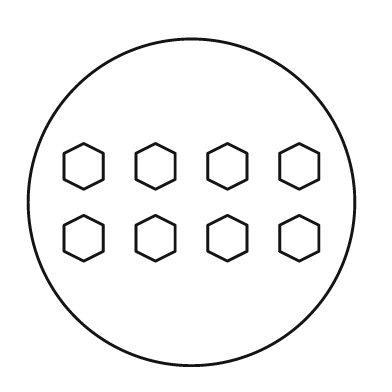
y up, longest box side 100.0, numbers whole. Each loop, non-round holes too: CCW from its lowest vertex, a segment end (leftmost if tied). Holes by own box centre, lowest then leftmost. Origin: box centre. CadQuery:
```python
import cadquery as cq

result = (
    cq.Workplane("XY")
    .moveTo(0.0, 0.0)
    .circle(50.0)
    .moveTo(-33.0, -18.0)
    .lineTo(-27.0, -15.0)
    .lineTo(-27.0, -7.0)
    .lineTo(-33.0, -4.0)
    .lineTo(-39.0, -7.0)
    .lineTo(-39.0, -15.0)
    .close()
    .moveTo(-11.0, -18.0)
    .lineTo(-5.0, -15.0)
    .lineTo(-5.0, -7.0)
    .lineTo(-11.0, -4.0)
    .lineTo(-17.0, -7.0)
    .lineTo(-17.0, -15.0)
    .close()
    .moveTo(11.0, -18.0)
    .lineTo(17.0, -15.0)
    .lineTo(17.0, -7.0)
    .lineTo(11.0, -4.0)
    .lineTo(5.0, -7.0)
    .lineTo(5.0, -15.0)
    .close()
    .moveTo(33.0, -18.0)
    .lineTo(39.0, -15.0)
    .lineTo(39.0, -7.0)
    .lineTo(33.0, -4.0)
    .lineTo(27.0, -7.0)
    .lineTo(27.0, -15.0)
    .close()
    .moveTo(-33.0, 4.0)
    .lineTo(-27.0, 7.0)
    .lineTo(-27.0, 15.0)
    .lineTo(-33.0, 18.0)
    .lineTo(-39.0, 15.0)
    .lineTo(-39.0, 7.0)
    .close()
    .moveTo(-11.0, 4.0)
    .lineTo(-5.0, 7.0)
    .lineTo(-5.0, 15.0)
    .lineTo(-11.0, 18.0)
    .lineTo(-17.0, 15.0)
    .lineTo(-17.0, 7.0)
    .close()
    .moveTo(11.0, 4.0)
    .lineTo(17.0, 7.0)
    .lineTo(17.0, 15.0)
    .lineTo(11.0, 18.0)
    .lineTo(5.0, 15.0)
    .lineTo(5.0, 7.0)
    .close()
    .moveTo(33.0, 4.0)
    .lineTo(39.0, 7.0)
    .lineTo(39.0, 15.0)
    .lineTo(33.0, 18.0)
    .lineTo(27.0, 15.0)
    .lineTo(27.0, 7.0)
    .close()
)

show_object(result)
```